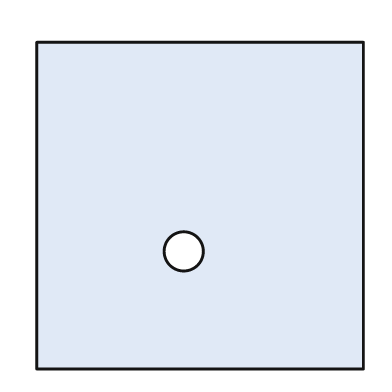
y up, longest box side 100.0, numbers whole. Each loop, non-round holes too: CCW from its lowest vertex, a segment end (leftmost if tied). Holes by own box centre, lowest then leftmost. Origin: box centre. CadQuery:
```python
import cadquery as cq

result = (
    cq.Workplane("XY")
    .moveTo(-50.0, -50.0)
    .lineTo(50.0, -50.0)
    .lineTo(50.0, 50.0)
    .lineTo(-50.0, 50.0)
    .close()
    .moveTo(-5.0, -14.0)
    .circle(6.0)
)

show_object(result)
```